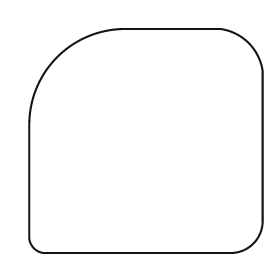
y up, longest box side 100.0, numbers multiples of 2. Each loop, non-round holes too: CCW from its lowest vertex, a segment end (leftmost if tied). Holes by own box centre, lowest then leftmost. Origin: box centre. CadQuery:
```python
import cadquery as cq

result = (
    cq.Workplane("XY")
    .moveTo(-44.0, -48.0)
    .lineTo(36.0, -48.0)
    .threePointArc((46.0, -44.0), (50.0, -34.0))
    .lineTo(50.0, 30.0)
    .threePointArc((44.0, 42.0), (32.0, 48.0))
    .lineTo(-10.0, 48.0)
    .threePointArc((-38.0, 36.0), (-50.0, 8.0))
    .lineTo(-50.0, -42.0)
    .threePointArc((-48.0, -46.0), (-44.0, -48.0))
    .close()
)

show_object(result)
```